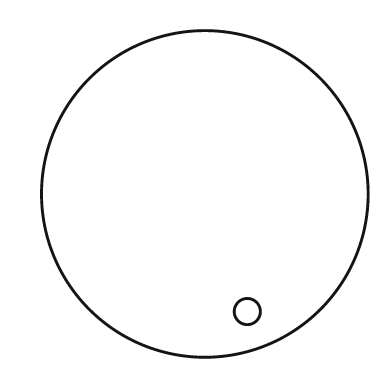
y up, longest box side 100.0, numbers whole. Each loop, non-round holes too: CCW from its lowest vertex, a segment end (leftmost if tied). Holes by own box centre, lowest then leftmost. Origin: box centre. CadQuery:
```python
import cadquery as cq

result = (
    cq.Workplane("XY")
    .moveTo(0.0, 0.0)
    .circle(50.0)
    .moveTo(13.0, -36.0)
    .circle(4.0)
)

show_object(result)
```